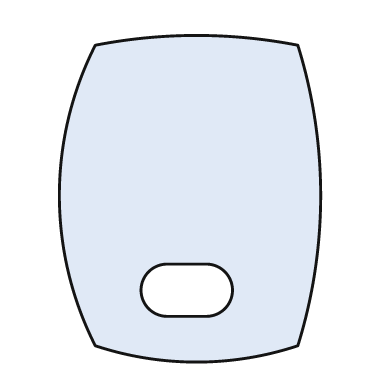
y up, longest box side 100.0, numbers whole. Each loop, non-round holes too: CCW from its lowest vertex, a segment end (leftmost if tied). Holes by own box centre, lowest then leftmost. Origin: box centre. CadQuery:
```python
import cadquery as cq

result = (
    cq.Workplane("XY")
    .moveTo(-29.0, -45.0)
    .threePointArc((2.0, -50.0), (33.0, -45.0))
    .threePointArc((40.0, 1.0), (33.0, 47.0))
    .threePointArc((2.0, 50.0), (-29.0, 47.0))
    .threePointArc((-40.0, 1.0), (-29.0, -45.0))
    .close()
    .moveTo(-7.0, -36.0)
    .lineTo(5.0, -36.0)
    .threePointArc((13.0, -28.0), (5.0, -20.0))
    .lineTo(-7.0, -20.0)
    .threePointArc((-15.0, -28.0), (-7.0, -36.0))
    .close()
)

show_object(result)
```